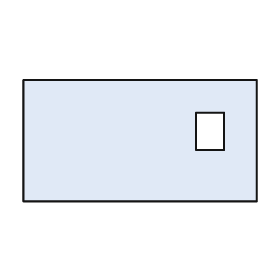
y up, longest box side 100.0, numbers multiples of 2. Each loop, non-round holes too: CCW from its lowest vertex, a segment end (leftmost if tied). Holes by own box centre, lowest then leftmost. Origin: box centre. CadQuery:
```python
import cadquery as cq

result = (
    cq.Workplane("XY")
    .moveTo(-50.0, -26.0)
    .lineTo(50.0, -26.0)
    .lineTo(50.0, 26.0)
    .lineTo(-50.0, 26.0)
    .close()
    .moveTo(24.0, -4.0)
    .lineTo(36.0, -4.0)
    .lineTo(36.0, 12.0)
    .lineTo(24.0, 12.0)
    .close()
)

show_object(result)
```